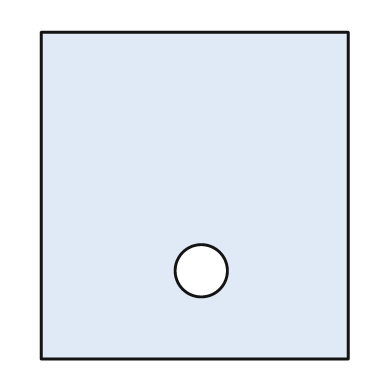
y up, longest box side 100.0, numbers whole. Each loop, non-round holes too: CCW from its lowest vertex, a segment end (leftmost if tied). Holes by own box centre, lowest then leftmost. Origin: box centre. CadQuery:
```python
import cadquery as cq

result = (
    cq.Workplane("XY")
    .moveTo(-47.0, -50.0)
    .lineTo(47.0, -50.0)
    .lineTo(47.0, 50.0)
    .lineTo(-47.0, 50.0)
    .close()
    .moveTo(2.0, -23.0)
    .circle(8.0)
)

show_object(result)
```